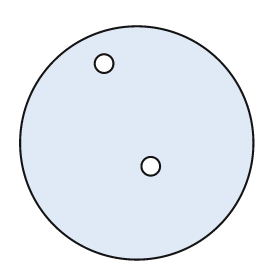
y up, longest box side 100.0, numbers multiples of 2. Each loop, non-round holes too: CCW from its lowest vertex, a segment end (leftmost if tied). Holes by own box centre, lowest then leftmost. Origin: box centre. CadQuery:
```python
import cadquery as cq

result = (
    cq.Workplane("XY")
    .moveTo(0.0, 0.0)
    .circle(50.0)
    .moveTo(6.0, -10.0)
    .circle(4.0)
    .moveTo(-14.0, 34.0)
    .circle(4.0)
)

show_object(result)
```